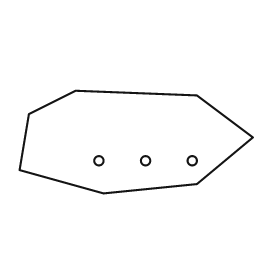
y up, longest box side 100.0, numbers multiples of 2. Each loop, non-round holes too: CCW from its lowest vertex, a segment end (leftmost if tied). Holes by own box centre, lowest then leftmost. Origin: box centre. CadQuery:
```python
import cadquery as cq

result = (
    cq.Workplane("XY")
    .moveTo(-14.0, -22.0)
    .lineTo(26.0, -18.0)
    .lineTo(50.0, 2.0)
    .lineTo(26.0, 20.0)
    .lineTo(-26.0, 22.0)
    .lineTo(-46.0, 12.0)
    .lineTo(-50.0, -12.0)
    .close()
    .moveTo(-16.0, -8.0)
    .circle(2.0)
    .moveTo(4.0, -8.0)
    .circle(2.0)
    .moveTo(24.0, -8.0)
    .circle(2.0)
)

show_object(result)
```